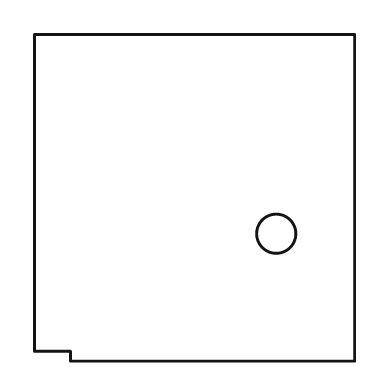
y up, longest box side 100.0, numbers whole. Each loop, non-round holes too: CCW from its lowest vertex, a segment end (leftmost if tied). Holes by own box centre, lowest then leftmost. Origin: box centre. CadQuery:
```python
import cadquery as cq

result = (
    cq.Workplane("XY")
    .moveTo(-38.0, -50.0)
    .lineTo(49.0, -50.0)
    .lineTo(49.0, 50.0)
    .lineTo(-49.0, 50.0)
    .lineTo(-49.0, -47.0)
    .lineTo(-38.0, -47.0)
    .close()
    .moveTo(25.0, -11.0)
    .circle(6.0)
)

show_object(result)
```